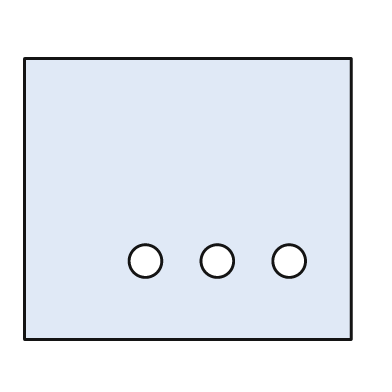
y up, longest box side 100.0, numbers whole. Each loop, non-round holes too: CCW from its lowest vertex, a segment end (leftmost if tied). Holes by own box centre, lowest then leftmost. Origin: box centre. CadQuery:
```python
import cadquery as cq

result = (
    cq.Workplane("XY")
    .moveTo(-50.0, -43.0)
    .lineTo(50.0, -43.0)
    .lineTo(50.0, 43.0)
    .lineTo(-50.0, 43.0)
    .close()
    .moveTo(-13.0, -19.0)
    .circle(5.0)
    .moveTo(9.0, -19.0)
    .circle(5.0)
    .moveTo(31.0, -19.0)
    .circle(5.0)
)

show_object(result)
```